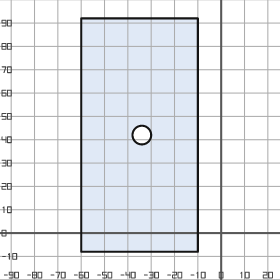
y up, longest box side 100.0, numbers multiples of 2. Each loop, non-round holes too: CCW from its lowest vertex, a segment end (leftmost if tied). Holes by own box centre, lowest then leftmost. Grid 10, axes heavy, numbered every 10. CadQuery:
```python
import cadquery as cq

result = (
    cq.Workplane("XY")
    .moveTo(-60.0, -8.0)
    .lineTo(-10.0, -8.0)
    .lineTo(-10.0, 92.0)
    .lineTo(-60.0, 92.0)
    .close()
    .moveTo(-34.0, 42.0)
    .circle(4.0)
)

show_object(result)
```